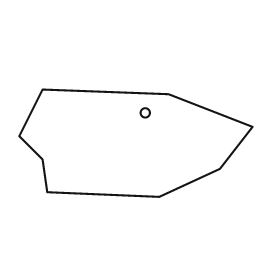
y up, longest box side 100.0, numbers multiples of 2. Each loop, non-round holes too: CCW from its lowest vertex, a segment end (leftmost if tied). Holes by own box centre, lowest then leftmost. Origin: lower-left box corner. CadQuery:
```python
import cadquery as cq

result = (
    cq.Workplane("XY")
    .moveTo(60.0, 0.0)
    .lineTo(86.0, 12.0)
    .lineTo(100.0, 30.0)
    .lineTo(64.0, 44.0)
    .lineTo(10.0, 46.0)
    .lineTo(0.0, 26.0)
    .lineTo(10.0, 16.0)
    .lineTo(12.0, 2.0)
    .close()
    .moveTo(54.0, 36.0)
    .circle(2.0)
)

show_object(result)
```